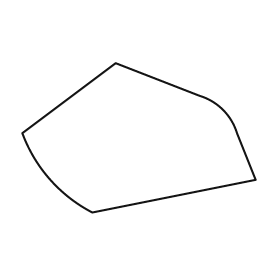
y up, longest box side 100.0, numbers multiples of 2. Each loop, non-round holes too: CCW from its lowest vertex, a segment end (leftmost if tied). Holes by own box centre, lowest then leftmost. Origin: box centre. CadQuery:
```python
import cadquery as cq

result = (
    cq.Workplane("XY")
    .moveTo(-20.0, -32.0)
    .lineTo(50.0, -18.0)
    .lineTo(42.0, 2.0)
    .threePointArc((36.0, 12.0), (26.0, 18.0))
    .lineTo(-10.0, 32.0)
    .lineTo(-50.0, 2.0)
    .threePointArc((-38.0, -18.0), (-20.0, -32.0))
    .close()
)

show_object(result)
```